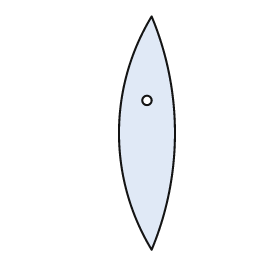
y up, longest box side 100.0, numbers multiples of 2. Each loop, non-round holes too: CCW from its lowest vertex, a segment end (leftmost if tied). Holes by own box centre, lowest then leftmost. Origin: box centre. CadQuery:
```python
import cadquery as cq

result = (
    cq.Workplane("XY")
    .moveTo(2.0, -50.0)
    .threePointArc((12.0, 0.0), (2.0, 50.0))
    .threePointArc((-12.0, 0.0), (2.0, -50.0))
    .close()
    .moveTo(0.0, 14.0)
    .circle(2.0)
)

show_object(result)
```